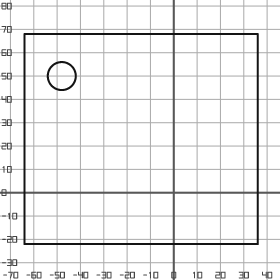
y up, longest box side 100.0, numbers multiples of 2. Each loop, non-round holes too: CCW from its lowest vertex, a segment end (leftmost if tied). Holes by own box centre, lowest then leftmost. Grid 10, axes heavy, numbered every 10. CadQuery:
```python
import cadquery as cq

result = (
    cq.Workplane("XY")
    .moveTo(-64.0, -22.0)
    .lineTo(36.0, -22.0)
    .lineTo(36.0, 68.0)
    .lineTo(-64.0, 68.0)
    .close()
    .moveTo(-48.0, 50.0)
    .circle(6.0)
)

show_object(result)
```